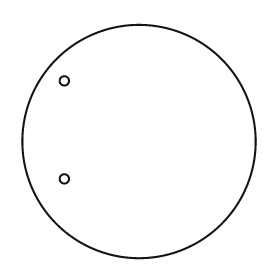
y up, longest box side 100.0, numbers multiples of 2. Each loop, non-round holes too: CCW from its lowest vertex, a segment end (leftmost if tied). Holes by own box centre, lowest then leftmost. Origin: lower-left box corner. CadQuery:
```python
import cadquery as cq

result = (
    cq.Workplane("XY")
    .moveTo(50.0, 50.0)
    .circle(50.0)
    .moveTo(18.0, 34.0)
    .circle(2.0)
    .moveTo(18.0, 76.0)
    .circle(2.0)
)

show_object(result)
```